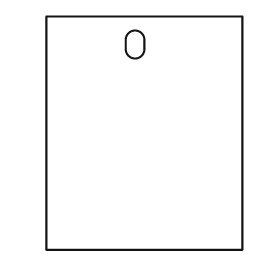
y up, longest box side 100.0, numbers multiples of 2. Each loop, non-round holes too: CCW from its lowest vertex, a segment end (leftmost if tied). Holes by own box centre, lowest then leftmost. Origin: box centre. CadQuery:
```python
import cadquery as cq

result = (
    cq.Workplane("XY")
    .moveTo(-42.0, -50.0)
    .lineTo(42.0, -50.0)
    .lineTo(42.0, 50.0)
    .lineTo(-42.0, 50.0)
    .close()
    .moveTo(-8.0, 36.0)
    .threePointArc((-4.0, 32.0), (0.0, 36.0))
    .lineTo(0.0, 40.0)
    .threePointArc((-4.0, 44.0), (-8.0, 40.0))
    .close()
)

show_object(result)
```